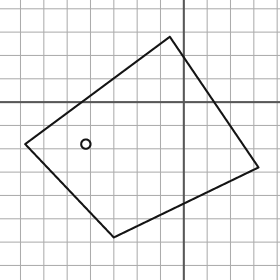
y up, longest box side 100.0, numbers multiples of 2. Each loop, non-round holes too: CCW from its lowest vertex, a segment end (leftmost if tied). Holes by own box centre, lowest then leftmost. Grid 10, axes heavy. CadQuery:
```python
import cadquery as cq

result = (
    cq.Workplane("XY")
    .moveTo(-30.0, -58.0)
    .lineTo(32.0, -28.0)
    .lineTo(-6.0, 28.0)
    .lineTo(-68.0, -18.0)
    .close()
    .moveTo(-42.0, -18.0)
    .circle(2.0)
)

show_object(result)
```